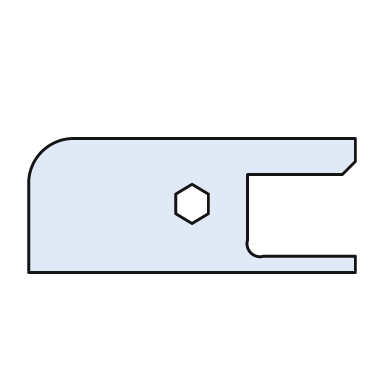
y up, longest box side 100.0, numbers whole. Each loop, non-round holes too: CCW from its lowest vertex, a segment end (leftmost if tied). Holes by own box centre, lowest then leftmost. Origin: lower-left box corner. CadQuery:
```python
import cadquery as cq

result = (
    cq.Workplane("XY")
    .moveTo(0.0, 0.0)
    .lineTo(100.0, 0.0)
    .lineTo(100.0, 5.0)
    .lineTo(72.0, 5.0)
    .threePointArc((68.0, 6.0), (67.0, 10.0))
    .lineTo(67.0, 30.0)
    .lineTo(96.0, 30.0)
    .lineTo(100.0, 34.0)
    .lineTo(100.0, 41.0)
    .lineTo(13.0, 41.0)
    .threePointArc((4.0, 37.0), (0.0, 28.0))
    .close()
    .moveTo(50.0, 15.0)
    .lineTo(55.0, 18.0)
    .lineTo(55.0, 24.0)
    .lineTo(50.0, 27.0)
    .lineTo(45.0, 24.0)
    .lineTo(45.0, 18.0)
    .close()
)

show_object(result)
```